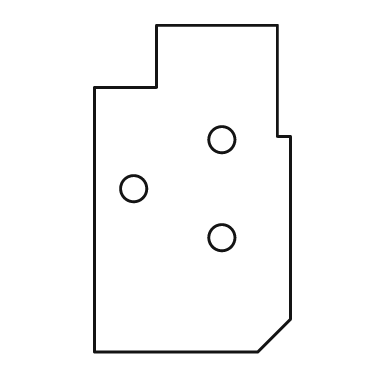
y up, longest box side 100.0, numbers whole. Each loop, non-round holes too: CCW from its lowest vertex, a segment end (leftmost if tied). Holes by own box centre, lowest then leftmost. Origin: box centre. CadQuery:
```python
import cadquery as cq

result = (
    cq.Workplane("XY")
    .moveTo(-30.0, -50.0)
    .lineTo(20.0, -50.0)
    .lineTo(30.0, -40.0)
    .lineTo(30.0, 16.0)
    .lineTo(26.0, 16.0)
    .lineTo(26.0, 50.0)
    .lineTo(-11.0, 50.0)
    .lineTo(-11.0, 31.0)
    .lineTo(-30.0, 31.0)
    .close()
    .moveTo(9.0, -15.0)
    .circle(4.0)
    .moveTo(-18.0, 0.0)
    .circle(4.0)
    .moveTo(9.0, 15.0)
    .circle(4.0)
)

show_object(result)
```